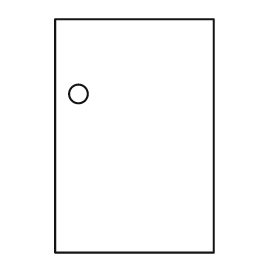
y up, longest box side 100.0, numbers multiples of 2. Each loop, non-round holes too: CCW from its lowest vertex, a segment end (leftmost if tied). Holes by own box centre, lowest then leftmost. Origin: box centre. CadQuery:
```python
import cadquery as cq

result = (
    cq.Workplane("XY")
    .moveTo(-34.0, -50.0)
    .lineTo(34.0, -50.0)
    .lineTo(34.0, 50.0)
    .lineTo(-34.0, 50.0)
    .close()
    .moveTo(-24.0, 18.0)
    .circle(4.0)
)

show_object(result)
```